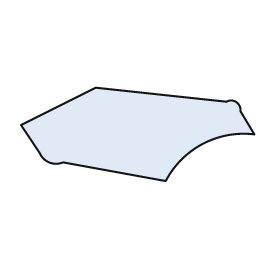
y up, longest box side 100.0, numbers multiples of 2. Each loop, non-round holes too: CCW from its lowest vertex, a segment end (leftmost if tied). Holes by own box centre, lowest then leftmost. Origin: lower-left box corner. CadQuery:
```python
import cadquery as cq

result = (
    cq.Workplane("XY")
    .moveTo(62.0, 0.0)
    .threePointArc((78.0, 16.0), (100.0, 20.0))
    .lineTo(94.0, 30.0)
    .threePointArc((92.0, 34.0), (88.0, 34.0))
    .lineTo(32.0, 40.0)
    .lineTo(0.0, 24.0)
    .lineTo(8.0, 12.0)
    .threePointArc((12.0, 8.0), (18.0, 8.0))
    .close()
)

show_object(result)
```